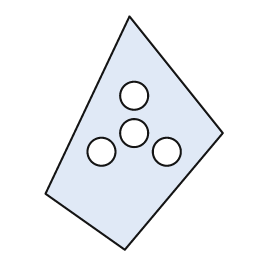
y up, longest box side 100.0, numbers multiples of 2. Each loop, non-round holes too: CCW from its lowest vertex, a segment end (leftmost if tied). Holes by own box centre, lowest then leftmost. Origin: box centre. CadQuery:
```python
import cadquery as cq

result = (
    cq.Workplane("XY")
    .moveTo(-4.0, -50.0)
    .lineTo(38.0, 0.0)
    .lineTo(-2.0, 50.0)
    .lineTo(-38.0, -26.0)
    .close()
    .moveTo(-14.0, -8.0)
    .circle(6.0)
    .moveTo(14.0, -8.0)
    .circle(6.0)
    .moveTo(0.0, 0.0)
    .circle(6.0)
    .moveTo(0.0, 16.0)
    .circle(6.0)
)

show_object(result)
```